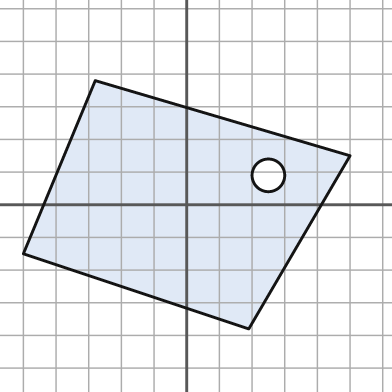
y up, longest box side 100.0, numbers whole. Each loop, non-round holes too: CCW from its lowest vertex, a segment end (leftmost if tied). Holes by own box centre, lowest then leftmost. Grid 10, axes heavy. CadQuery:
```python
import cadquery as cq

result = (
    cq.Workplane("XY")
    .moveTo(19.0, -38.0)
    .lineTo(50.0, 15.0)
    .lineTo(-28.0, 38.0)
    .lineTo(-50.0, -15.0)
    .close()
    .moveTo(25.0, 9.0)
    .circle(5.0)
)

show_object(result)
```